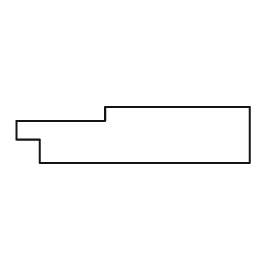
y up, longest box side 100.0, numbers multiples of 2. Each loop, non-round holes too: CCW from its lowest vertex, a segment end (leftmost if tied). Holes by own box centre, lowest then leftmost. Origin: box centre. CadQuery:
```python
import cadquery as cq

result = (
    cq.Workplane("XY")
    .moveTo(-40.0, -12.0)
    .lineTo(50.0, -12.0)
    .lineTo(50.0, 12.0)
    .lineTo(-12.0, 12.0)
    .lineTo(-12.0, 6.0)
    .lineTo(-50.0, 6.0)
    .lineTo(-50.0, -2.0)
    .lineTo(-40.0, -2.0)
    .close()
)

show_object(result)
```